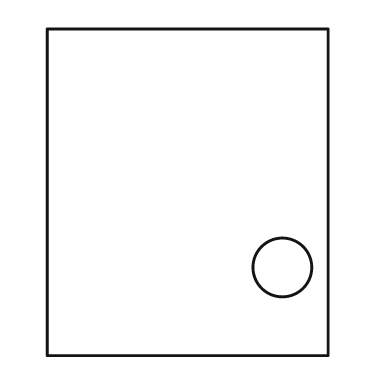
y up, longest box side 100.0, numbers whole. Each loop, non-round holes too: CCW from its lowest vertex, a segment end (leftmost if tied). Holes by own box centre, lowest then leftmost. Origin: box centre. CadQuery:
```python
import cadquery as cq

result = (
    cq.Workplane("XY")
    .moveTo(-43.0, -50.0)
    .lineTo(43.0, -50.0)
    .lineTo(43.0, 50.0)
    .lineTo(-43.0, 50.0)
    .close()
    .moveTo(29.0, -23.0)
    .circle(9.0)
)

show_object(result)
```